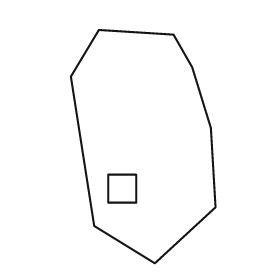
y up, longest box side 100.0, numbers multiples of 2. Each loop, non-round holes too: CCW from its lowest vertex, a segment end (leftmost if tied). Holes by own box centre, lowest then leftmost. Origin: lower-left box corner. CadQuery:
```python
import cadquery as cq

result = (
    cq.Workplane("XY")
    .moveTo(36.0, 0.0)
    .lineTo(62.0, 24.0)
    .lineTo(60.0, 58.0)
    .lineTo(52.0, 84.0)
    .lineTo(44.0, 98.0)
    .lineTo(12.0, 100.0)
    .lineTo(0.0, 80.0)
    .lineTo(10.0, 16.0)
    .close()
    .moveTo(16.0, 26.0)
    .lineTo(28.0, 26.0)
    .lineTo(28.0, 38.0)
    .lineTo(16.0, 38.0)
    .close()
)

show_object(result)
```